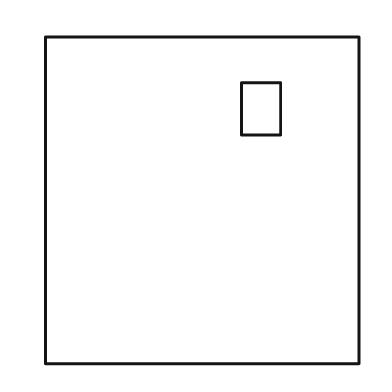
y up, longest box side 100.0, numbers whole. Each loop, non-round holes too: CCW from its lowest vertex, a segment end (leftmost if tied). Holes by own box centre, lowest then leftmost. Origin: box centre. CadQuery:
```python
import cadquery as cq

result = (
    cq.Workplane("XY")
    .moveTo(-48.0, -50.0)
    .lineTo(48.0, -50.0)
    .lineTo(48.0, 50.0)
    .lineTo(-48.0, 50.0)
    .close()
    .moveTo(12.0, 20.0)
    .lineTo(24.0, 20.0)
    .lineTo(24.0, 36.0)
    .lineTo(12.0, 36.0)
    .close()
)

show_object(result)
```